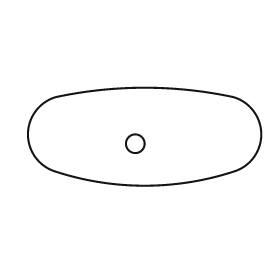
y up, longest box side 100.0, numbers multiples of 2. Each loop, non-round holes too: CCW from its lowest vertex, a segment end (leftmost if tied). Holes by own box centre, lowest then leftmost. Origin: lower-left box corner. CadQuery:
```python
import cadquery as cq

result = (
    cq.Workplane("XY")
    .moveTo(12.0, 6.0)
    .threePointArc((50.0, 0.0), (88.0, 6.0))
    .threePointArc((100.0, 22.0), (88.0, 38.0))
    .threePointArc((50.0, 42.0), (12.0, 38.0))
    .threePointArc((0.0, 22.0), (12.0, 6.0))
    .close()
    .moveTo(46.0, 18.0)
    .circle(4.0)
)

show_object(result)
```